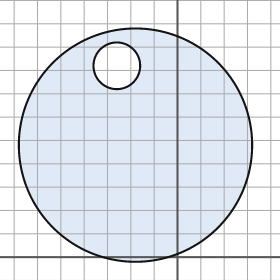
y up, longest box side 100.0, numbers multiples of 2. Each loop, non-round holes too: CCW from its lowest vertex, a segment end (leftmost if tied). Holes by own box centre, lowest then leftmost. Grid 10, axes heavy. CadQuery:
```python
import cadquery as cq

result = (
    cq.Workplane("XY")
    .moveTo(-18.0, 48.0)
    .circle(50.0)
    .moveTo(-26.0, 82.0)
    .circle(10.0)
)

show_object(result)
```